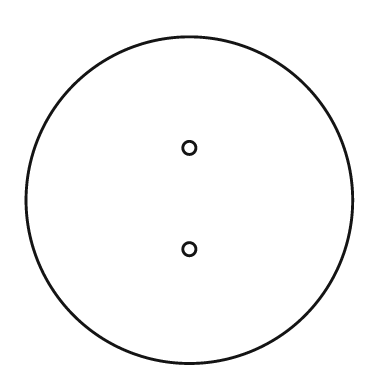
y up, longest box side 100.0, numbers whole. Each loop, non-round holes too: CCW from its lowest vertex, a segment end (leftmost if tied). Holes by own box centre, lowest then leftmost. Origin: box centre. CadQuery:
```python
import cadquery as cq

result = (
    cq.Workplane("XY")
    .moveTo(0.0, 0.0)
    .circle(50.0)
    .moveTo(0.0, -15.0)
    .circle(2.0)
    .moveTo(0.0, 16.0)
    .circle(2.0)
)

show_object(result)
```